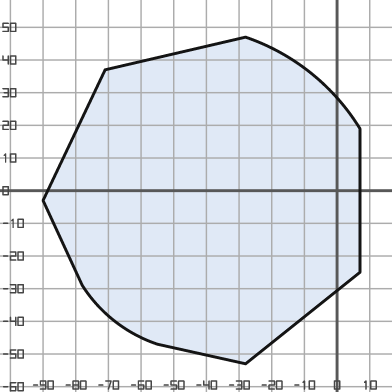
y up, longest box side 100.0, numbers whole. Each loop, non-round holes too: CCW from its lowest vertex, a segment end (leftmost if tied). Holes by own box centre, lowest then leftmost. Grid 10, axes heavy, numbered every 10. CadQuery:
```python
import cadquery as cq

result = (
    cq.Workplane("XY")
    .moveTo(-28.0, -53.0)
    .lineTo(7.0, -25.0)
    .lineTo(7.0, 19.0)
    .threePointArc((-8.0, 36.0), (-28.0, 47.0))
    .lineTo(-71.0, 37.0)
    .lineTo(-90.0, -3.0)
    .lineTo(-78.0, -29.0)
    .threePointArc((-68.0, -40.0), (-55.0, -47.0))
    .close()
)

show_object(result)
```